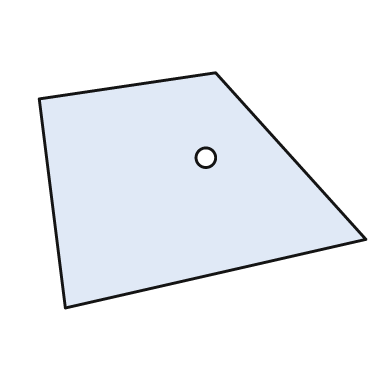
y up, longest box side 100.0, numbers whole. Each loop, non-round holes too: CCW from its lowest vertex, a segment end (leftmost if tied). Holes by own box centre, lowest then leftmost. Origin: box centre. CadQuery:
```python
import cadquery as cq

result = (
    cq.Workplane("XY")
    .moveTo(-42.0, -36.0)
    .lineTo(50.0, -15.0)
    .lineTo(4.0, 36.0)
    .lineTo(-50.0, 28.0)
    .close()
    .moveTo(1.0, 10.0)
    .circle(3.0)
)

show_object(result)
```